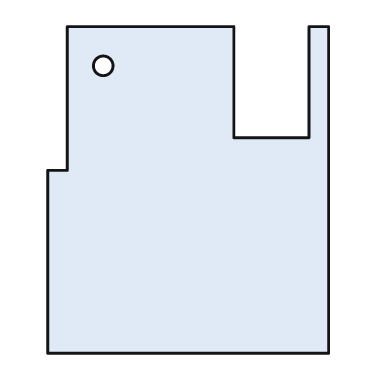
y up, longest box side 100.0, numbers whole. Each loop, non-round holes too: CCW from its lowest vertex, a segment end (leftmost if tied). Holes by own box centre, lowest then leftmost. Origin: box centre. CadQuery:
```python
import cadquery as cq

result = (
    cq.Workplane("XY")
    .moveTo(-43.0, -50.0)
    .lineTo(43.0, -50.0)
    .lineTo(43.0, 50.0)
    .lineTo(37.0, 50.0)
    .lineTo(37.0, 16.0)
    .lineTo(14.0, 16.0)
    .lineTo(14.0, 50.0)
    .lineTo(-37.0, 50.0)
    .lineTo(-37.0, 6.0)
    .lineTo(-43.0, 6.0)
    .close()
    .moveTo(-26.0, 38.0)
    .circle(3.0)
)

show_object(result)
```